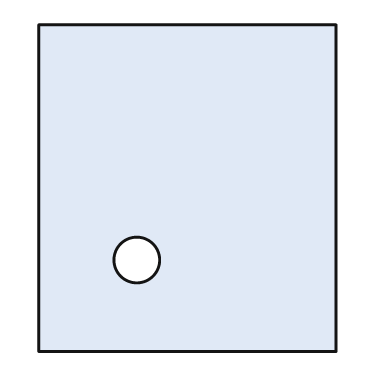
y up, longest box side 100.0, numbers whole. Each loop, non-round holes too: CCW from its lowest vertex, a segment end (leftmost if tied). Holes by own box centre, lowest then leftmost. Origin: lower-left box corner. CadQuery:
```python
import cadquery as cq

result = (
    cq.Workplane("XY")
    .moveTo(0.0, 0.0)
    .lineTo(91.0, 0.0)
    .lineTo(91.0, 100.0)
    .lineTo(0.0, 100.0)
    .close()
    .moveTo(30.0, 28.0)
    .circle(7.0)
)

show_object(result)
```